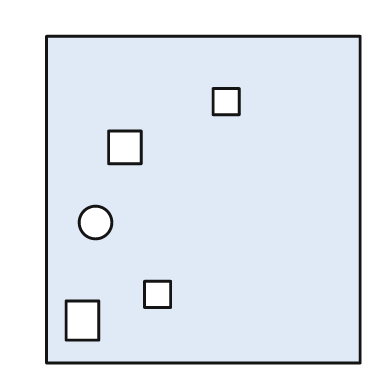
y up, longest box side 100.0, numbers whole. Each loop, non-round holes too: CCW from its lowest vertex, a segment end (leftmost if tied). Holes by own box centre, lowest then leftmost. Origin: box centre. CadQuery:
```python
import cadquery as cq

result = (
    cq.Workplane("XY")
    .moveTo(-48.0, -50.0)
    .lineTo(48.0, -50.0)
    .lineTo(48.0, 50.0)
    .lineTo(-48.0, 50.0)
    .close()
    .moveTo(-42.0, -43.0)
    .lineTo(-32.0, -43.0)
    .lineTo(-32.0, -31.0)
    .lineTo(-42.0, -31.0)
    .close()
    .moveTo(-18.0, -33.0)
    .lineTo(-10.0, -33.0)
    .lineTo(-10.0, -25.0)
    .lineTo(-18.0, -25.0)
    .close()
    .moveTo(-33.0, -7.0)
    .circle(5.0)
    .moveTo(-29.0, 11.0)
    .lineTo(-19.0, 11.0)
    .lineTo(-19.0, 21.0)
    .lineTo(-29.0, 21.0)
    .close()
    .moveTo(3.0, 26.0)
    .lineTo(11.0, 26.0)
    .lineTo(11.0, 34.0)
    .lineTo(3.0, 34.0)
    .close()
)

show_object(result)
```